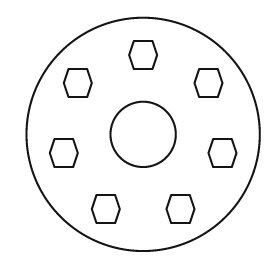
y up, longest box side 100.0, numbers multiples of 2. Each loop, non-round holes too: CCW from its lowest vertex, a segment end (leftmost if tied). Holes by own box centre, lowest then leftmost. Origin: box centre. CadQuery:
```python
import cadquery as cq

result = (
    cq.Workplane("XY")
    .moveTo(0.0, 0.0)
    .circle(50.0)
    .moveTo(-20.0, -38.0)
    .lineTo(-12.0, -38.0)
    .lineTo(-10.0, -32.0)
    .lineTo(-12.0, -26.0)
    .lineTo(-20.0, -26.0)
    .lineTo(-22.0, -32.0)
    .close()
    .moveTo(12.0, -38.0)
    .lineTo(20.0, -38.0)
    .lineTo(22.0, -32.0)
    .lineTo(20.0, -26.0)
    .lineTo(12.0, -26.0)
    .lineTo(10.0, -32.0)
    .close()
    .moveTo(-38.0, -14.0)
    .lineTo(-30.0, -14.0)
    .lineTo(-28.0, -8.0)
    .lineTo(-30.0, -2.0)
    .lineTo(-38.0, -2.0)
    .lineTo(-40.0, -8.0)
    .close()
    .moveTo(30.0, -14.0)
    .lineTo(38.0, -14.0)
    .lineTo(40.0, -8.0)
    .lineTo(38.0, -2.0)
    .lineTo(30.0, -2.0)
    .lineTo(28.0, -8.0)
    .close()
    .moveTo(0.0, 0.0)
    .circle(14.0)
    .moveTo(-32.0, 16.0)
    .lineTo(-24.0, 16.0)
    .lineTo(-22.0, 22.0)
    .lineTo(-24.0, 28.0)
    .lineTo(-32.0, 28.0)
    .lineTo(-34.0, 22.0)
    .close()
    .moveTo(24.0, 16.0)
    .lineTo(32.0, 16.0)
    .lineTo(34.0, 22.0)
    .lineTo(32.0, 28.0)
    .lineTo(24.0, 28.0)
    .lineTo(22.0, 22.0)
    .close()
    .moveTo(-4.0, 28.0)
    .lineTo(4.0, 28.0)
    .lineTo(6.0, 34.0)
    .lineTo(4.0, 40.0)
    .lineTo(-4.0, 40.0)
    .lineTo(-6.0, 34.0)
    .close()
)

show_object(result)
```